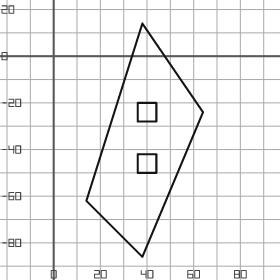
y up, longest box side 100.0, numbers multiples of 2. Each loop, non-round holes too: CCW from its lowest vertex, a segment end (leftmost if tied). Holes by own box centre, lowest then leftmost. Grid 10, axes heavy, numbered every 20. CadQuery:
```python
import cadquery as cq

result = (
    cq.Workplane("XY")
    .moveTo(38.0, -86.0)
    .lineTo(64.0, -24.0)
    .lineTo(38.0, 14.0)
    .lineTo(14.0, -62.0)
    .close()
    .moveTo(36.0, -50.0)
    .lineTo(44.0, -50.0)
    .lineTo(44.0, -42.0)
    .lineTo(36.0, -42.0)
    .close()
    .moveTo(36.0, -28.0)
    .lineTo(44.0, -28.0)
    .lineTo(44.0, -20.0)
    .lineTo(36.0, -20.0)
    .close()
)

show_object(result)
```